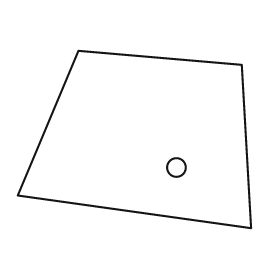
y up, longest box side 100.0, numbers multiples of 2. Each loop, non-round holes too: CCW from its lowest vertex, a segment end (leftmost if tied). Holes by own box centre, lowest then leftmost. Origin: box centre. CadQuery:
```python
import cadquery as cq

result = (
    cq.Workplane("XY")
    .moveTo(50.0, -38.0)
    .lineTo(46.0, 32.0)
    .lineTo(-24.0, 38.0)
    .lineTo(-50.0, -24.0)
    .close()
    .moveTo(18.0, -12.0)
    .circle(4.0)
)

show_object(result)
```